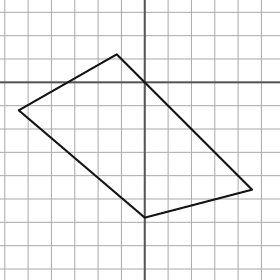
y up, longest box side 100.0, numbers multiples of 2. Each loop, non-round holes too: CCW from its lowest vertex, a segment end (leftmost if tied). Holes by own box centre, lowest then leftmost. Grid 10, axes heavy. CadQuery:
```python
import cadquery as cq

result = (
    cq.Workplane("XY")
    .moveTo(0.0, -58.0)
    .lineTo(46.0, -46.0)
    .lineTo(-12.0, 12.0)
    .lineTo(-54.0, -12.0)
    .close()
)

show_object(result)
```